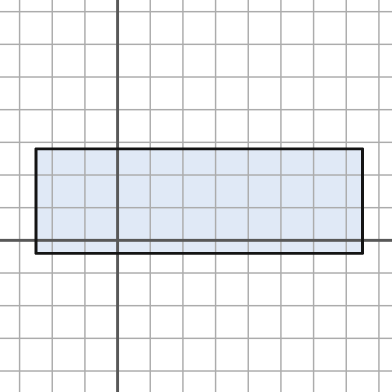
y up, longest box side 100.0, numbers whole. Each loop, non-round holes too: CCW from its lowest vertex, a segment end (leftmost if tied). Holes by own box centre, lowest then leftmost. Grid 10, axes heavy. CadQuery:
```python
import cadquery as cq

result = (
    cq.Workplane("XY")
    .moveTo(-25.0, -4.0)
    .lineTo(75.0, -4.0)
    .lineTo(75.0, 28.0)
    .lineTo(-25.0, 28.0)
    .close()
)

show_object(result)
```